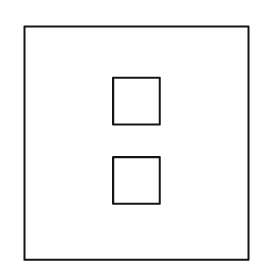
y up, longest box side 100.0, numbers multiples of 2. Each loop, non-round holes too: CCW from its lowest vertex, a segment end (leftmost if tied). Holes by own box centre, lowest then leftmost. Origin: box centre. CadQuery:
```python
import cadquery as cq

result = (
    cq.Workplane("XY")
    .moveTo(-48.0, -50.0)
    .lineTo(48.0, -50.0)
    .lineTo(48.0, 50.0)
    .lineTo(-48.0, 50.0)
    .close()
    .moveTo(-10.0, -26.0)
    .lineTo(10.0, -26.0)
    .lineTo(10.0, -6.0)
    .lineTo(-10.0, -6.0)
    .close()
    .moveTo(-10.0, 8.0)
    .lineTo(10.0, 8.0)
    .lineTo(10.0, 28.0)
    .lineTo(-10.0, 28.0)
    .close()
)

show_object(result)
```